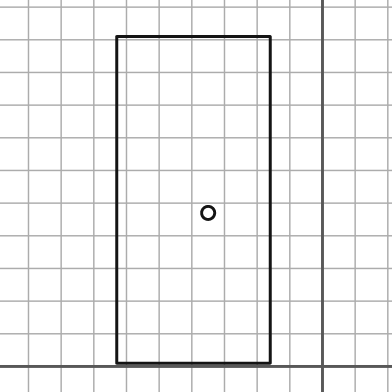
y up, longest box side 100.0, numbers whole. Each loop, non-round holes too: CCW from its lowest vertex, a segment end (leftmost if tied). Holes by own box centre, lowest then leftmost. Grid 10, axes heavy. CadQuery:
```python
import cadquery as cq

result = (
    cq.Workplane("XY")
    .moveTo(-63.0, 1.0)
    .lineTo(-16.0, 1.0)
    .lineTo(-16.0, 101.0)
    .lineTo(-63.0, 101.0)
    .close()
    .moveTo(-35.0, 47.0)
    .circle(2.0)
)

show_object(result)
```